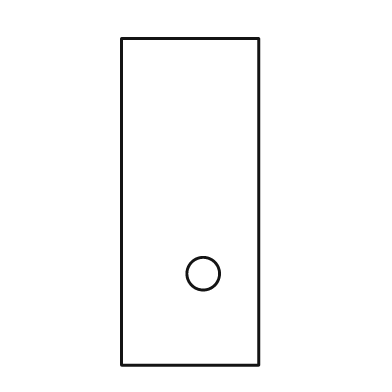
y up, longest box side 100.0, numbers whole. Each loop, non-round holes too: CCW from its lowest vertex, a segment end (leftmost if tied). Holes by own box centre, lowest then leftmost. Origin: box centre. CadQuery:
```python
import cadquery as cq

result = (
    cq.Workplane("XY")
    .moveTo(-21.0, -50.0)
    .lineTo(21.0, -50.0)
    .lineTo(21.0, 50.0)
    .lineTo(-21.0, 50.0)
    .close()
    .moveTo(4.0, -22.0)
    .circle(5.0)
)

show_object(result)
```